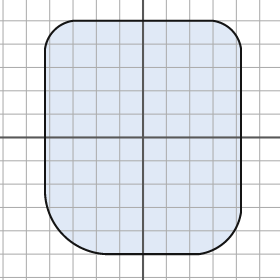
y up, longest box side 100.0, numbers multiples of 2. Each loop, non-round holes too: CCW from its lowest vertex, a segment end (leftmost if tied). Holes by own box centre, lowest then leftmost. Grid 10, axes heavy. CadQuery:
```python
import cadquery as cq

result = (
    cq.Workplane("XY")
    .moveTo(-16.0, -50.0)
    .lineTo(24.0, -50.0)
    .threePointArc((36.0, -44.0), (42.0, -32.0))
    .lineTo(42.0, 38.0)
    .threePointArc((38.0, 46.0), (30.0, 50.0))
    .lineTo(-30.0, 50.0)
    .threePointArc((-38.0, 46.0), (-42.0, 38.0))
    .lineTo(-42.0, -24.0)
    .threePointArc((-34.0, -42.0), (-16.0, -50.0))
    .close()
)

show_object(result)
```